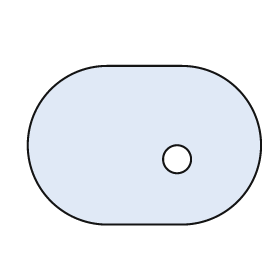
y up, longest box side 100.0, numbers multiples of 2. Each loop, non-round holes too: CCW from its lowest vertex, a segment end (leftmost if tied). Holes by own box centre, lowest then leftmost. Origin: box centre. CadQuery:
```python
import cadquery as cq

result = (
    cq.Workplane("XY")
    .moveTo(-16.0, -34.0)
    .lineTo(16.0, -34.0)
    .threePointArc((50.0, 0.0), (16.0, 34.0))
    .lineTo(-16.0, 34.0)
    .threePointArc((-50.0, 0.0), (-16.0, -34.0))
    .close()
    .moveTo(14.0, -6.0)
    .circle(6.0)
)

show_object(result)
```